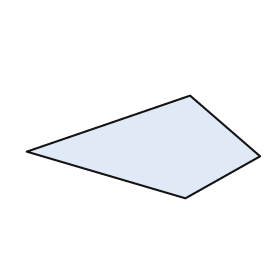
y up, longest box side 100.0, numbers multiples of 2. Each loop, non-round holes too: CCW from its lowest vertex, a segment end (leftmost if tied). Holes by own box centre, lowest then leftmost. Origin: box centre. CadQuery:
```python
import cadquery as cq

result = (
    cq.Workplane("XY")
    .moveTo(18.0, -22.0)
    .lineTo(50.0, -4.0)
    .lineTo(20.0, 22.0)
    .lineTo(-50.0, -2.0)
    .close()
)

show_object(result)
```